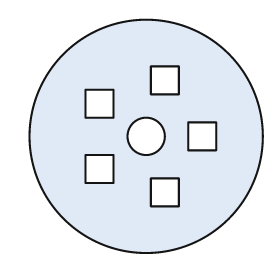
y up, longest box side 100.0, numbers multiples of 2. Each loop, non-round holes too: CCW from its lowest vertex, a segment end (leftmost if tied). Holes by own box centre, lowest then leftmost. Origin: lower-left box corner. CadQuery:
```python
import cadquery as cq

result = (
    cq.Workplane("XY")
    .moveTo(50.0, 50.0)
    .circle(50.0)
    .moveTo(52.0, 20.0)
    .lineTo(64.0, 20.0)
    .lineTo(64.0, 32.0)
    .lineTo(52.0, 32.0)
    .close()
    .moveTo(24.0, 30.0)
    .lineTo(36.0, 30.0)
    .lineTo(36.0, 42.0)
    .lineTo(24.0, 42.0)
    .close()
    .moveTo(50.0, 50.0)
    .circle(8.0)
    .moveTo(68.0, 44.0)
    .lineTo(80.0, 44.0)
    .lineTo(80.0, 56.0)
    .lineTo(68.0, 56.0)
    .close()
    .moveTo(24.0, 58.0)
    .lineTo(36.0, 58.0)
    .lineTo(36.0, 70.0)
    .lineTo(24.0, 70.0)
    .close()
    .moveTo(52.0, 68.0)
    .lineTo(64.0, 68.0)
    .lineTo(64.0, 80.0)
    .lineTo(52.0, 80.0)
    .close()
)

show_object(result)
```